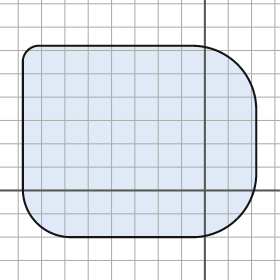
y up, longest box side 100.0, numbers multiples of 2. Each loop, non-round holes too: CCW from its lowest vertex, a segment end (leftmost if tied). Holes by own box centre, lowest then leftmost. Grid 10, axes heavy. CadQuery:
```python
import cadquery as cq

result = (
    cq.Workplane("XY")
    .moveTo(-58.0, -20.0)
    .lineTo(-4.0, -20.0)
    .threePointArc((14.0, -12.0), (22.0, 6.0))
    .lineTo(22.0, 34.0)
    .threePointArc((14.0, 54.0), (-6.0, 62.0))
    .lineTo(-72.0, 62.0)
    .threePointArc((-76.0, 60.0), (-78.0, 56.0))
    .lineTo(-78.0, 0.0)
    .threePointArc((-72.0, -14.0), (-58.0, -20.0))
    .close()
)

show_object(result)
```